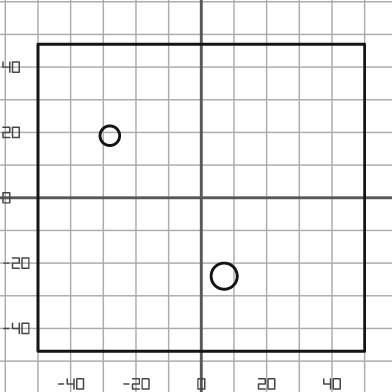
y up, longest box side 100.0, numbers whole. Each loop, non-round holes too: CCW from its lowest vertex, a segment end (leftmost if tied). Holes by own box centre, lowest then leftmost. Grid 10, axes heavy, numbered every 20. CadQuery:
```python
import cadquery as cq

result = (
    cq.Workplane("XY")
    .moveTo(-50.0, -47.0)
    .lineTo(50.0, -47.0)
    .lineTo(50.0, 47.0)
    .lineTo(-50.0, 47.0)
    .close()
    .moveTo(7.0, -24.0)
    .circle(4.0)
    .moveTo(-28.0, 19.0)
    .circle(3.0)
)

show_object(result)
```